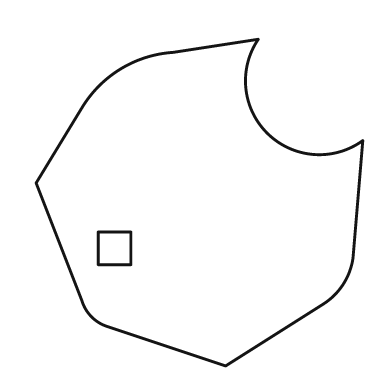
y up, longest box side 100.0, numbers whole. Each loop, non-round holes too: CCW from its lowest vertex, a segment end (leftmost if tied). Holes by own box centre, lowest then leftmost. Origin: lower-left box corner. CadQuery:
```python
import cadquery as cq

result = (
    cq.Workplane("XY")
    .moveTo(58.0, 0.0)
    .lineTo(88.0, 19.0)
    .threePointArc((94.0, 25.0), (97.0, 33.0))
    .lineTo(100.0, 69.0)
    .threePointArc((71.0, 71.0), (68.0, 100.0))
    .lineTo(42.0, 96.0)
    .threePointArc((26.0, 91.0), (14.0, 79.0))
    .lineTo(0.0, 56.0)
    .lineTo(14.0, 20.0)
    .threePointArc((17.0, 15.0), (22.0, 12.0))
    .close()
    .moveTo(19.0, 31.0)
    .lineTo(29.0, 31.0)
    .lineTo(29.0, 41.0)
    .lineTo(19.0, 41.0)
    .close()
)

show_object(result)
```